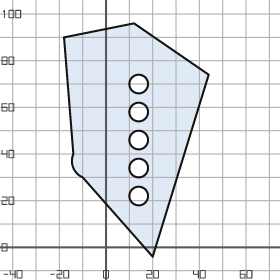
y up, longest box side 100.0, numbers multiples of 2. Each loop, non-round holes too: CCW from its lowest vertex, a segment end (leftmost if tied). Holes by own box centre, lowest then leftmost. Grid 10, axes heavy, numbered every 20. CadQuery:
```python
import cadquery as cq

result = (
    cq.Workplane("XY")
    .moveTo(20.0, -4.0)
    .lineTo(44.0, 74.0)
    .lineTo(12.0, 96.0)
    .lineTo(-18.0, 90.0)
    .lineTo(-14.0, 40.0)
    .threePointArc((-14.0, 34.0), (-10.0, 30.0))
    .close()
    .moveTo(14.0, 22.0)
    .circle(4.0)
    .moveTo(14.0, 34.0)
    .circle(4.0)
    .moveTo(14.0, 46.0)
    .circle(4.0)
    .moveTo(14.0, 58.0)
    .circle(4.0)
    .moveTo(14.0, 70.0)
    .circle(4.0)
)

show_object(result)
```